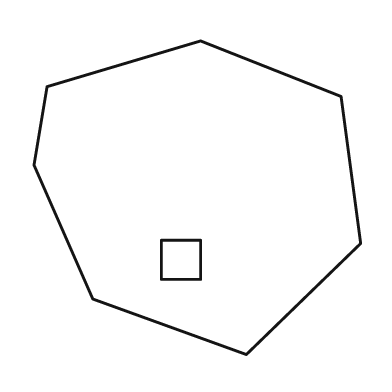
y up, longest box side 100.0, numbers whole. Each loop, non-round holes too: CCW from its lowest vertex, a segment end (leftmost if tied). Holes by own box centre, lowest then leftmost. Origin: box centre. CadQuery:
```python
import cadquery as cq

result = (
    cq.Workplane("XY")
    .moveTo(15.0, -48.0)
    .lineTo(50.0, -14.0)
    .lineTo(44.0, 31.0)
    .lineTo(1.0, 48.0)
    .lineTo(-46.0, 34.0)
    .lineTo(-50.0, 10.0)
    .lineTo(-32.0, -31.0)
    .close()
    .moveTo(-11.0, -25.0)
    .lineTo(1.0, -25.0)
    .lineTo(1.0, -13.0)
    .lineTo(-11.0, -13.0)
    .close()
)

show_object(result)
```